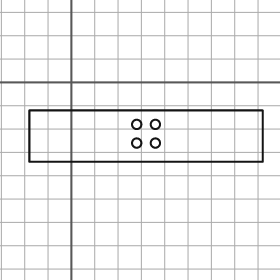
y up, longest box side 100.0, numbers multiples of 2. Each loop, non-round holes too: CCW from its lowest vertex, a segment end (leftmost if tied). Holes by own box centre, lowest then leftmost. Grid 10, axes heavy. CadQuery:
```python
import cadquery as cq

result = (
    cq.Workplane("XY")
    .moveTo(-18.0, -34.0)
    .lineTo(82.0, -34.0)
    .lineTo(82.0, -12.0)
    .lineTo(-18.0, -12.0)
    .close()
    .moveTo(28.0, -26.0)
    .circle(2.0)
    .moveTo(36.0, -26.0)
    .circle(2.0)
    .moveTo(28.0, -18.0)
    .circle(2.0)
    .moveTo(36.0, -18.0)
    .circle(2.0)
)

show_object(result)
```